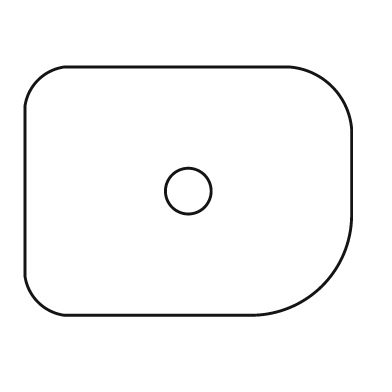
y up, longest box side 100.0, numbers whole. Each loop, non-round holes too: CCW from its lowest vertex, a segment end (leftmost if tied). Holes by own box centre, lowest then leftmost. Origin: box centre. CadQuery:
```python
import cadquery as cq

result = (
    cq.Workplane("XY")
    .moveTo(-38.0, -38.0)
    .lineTo(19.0, -38.0)
    .threePointArc((41.0, -29.0), (50.0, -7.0))
    .lineTo(50.0, 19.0)
    .threePointArc((44.0, 32.0), (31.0, 38.0))
    .lineTo(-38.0, 38.0)
    .threePointArc((-46.0, 34.0), (-50.0, 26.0))
    .lineTo(-50.0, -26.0)
    .threePointArc((-46.0, -34.0), (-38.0, -38.0))
    .close()
    .moveTo(0.0, 0.0)
    .circle(7.0)
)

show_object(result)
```